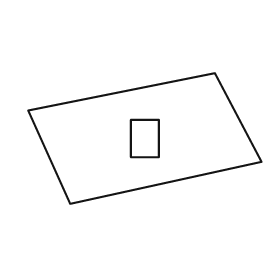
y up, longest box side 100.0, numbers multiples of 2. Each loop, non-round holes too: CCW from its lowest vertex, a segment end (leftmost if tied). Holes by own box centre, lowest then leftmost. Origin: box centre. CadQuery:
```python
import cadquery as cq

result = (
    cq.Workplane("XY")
    .moveTo(-32.0, -28.0)
    .lineTo(50.0, -10.0)
    .lineTo(30.0, 28.0)
    .lineTo(-50.0, 12.0)
    .close()
    .moveTo(-6.0, -8.0)
    .lineTo(6.0, -8.0)
    .lineTo(6.0, 8.0)
    .lineTo(-6.0, 8.0)
    .close()
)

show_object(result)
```